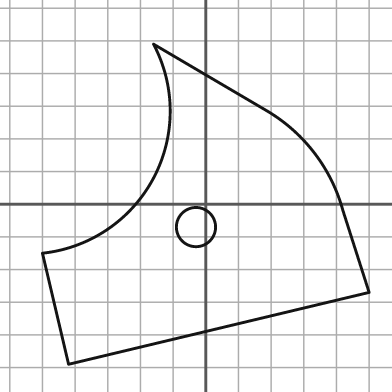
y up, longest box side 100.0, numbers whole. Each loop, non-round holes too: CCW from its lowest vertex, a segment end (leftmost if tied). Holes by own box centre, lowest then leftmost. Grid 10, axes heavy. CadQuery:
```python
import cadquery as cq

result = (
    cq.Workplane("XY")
    .moveTo(-42.0, -49.0)
    .lineTo(50.0, -27.0)
    .lineTo(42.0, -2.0)
    .threePointArc((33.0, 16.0), (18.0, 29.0))
    .lineTo(-16.0, 49.0)
    .threePointArc((-16.0, 8.0), (-50.0, -15.0))
    .close()
    .moveTo(-3.0, -7.0)
    .circle(6.0)
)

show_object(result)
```